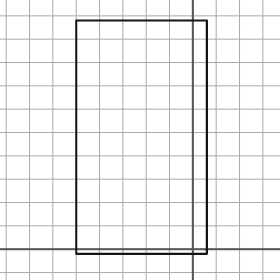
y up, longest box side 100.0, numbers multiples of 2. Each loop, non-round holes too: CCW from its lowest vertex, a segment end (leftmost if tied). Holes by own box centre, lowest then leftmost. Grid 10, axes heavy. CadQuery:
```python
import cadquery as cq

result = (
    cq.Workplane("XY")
    .moveTo(-50.0, -2.0)
    .lineTo(6.0, -2.0)
    .lineTo(6.0, 98.0)
    .lineTo(-50.0, 98.0)
    .close()
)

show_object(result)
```